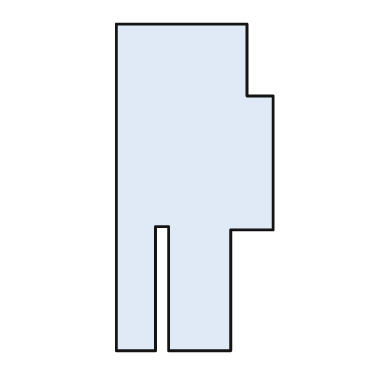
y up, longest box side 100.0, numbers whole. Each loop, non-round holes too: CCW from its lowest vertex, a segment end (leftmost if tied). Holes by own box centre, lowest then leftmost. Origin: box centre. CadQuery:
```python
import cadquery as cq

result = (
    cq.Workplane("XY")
    .moveTo(-24.0, -50.0)
    .lineTo(-12.0, -50.0)
    .lineTo(-12.0, -12.0)
    .lineTo(-8.0, -12.0)
    .lineTo(-8.0, -50.0)
    .lineTo(11.0, -50.0)
    .lineTo(11.0, -13.0)
    .lineTo(24.0, -13.0)
    .lineTo(24.0, 28.0)
    .lineTo(16.0, 28.0)
    .lineTo(16.0, 50.0)
    .lineTo(-24.0, 50.0)
    .close()
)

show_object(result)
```